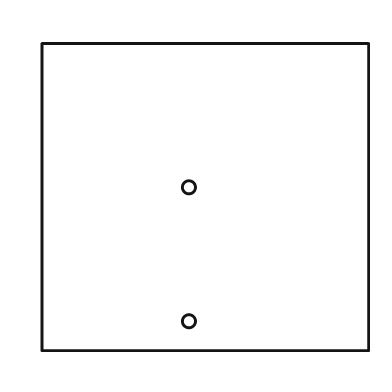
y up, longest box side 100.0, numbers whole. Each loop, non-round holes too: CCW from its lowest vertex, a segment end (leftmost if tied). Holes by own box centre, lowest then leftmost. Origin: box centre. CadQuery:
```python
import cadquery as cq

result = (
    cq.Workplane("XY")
    .moveTo(-50.0, -47.0)
    .lineTo(50.0, -47.0)
    .lineTo(50.0, 47.0)
    .lineTo(-50.0, 47.0)
    .close()
    .moveTo(-5.0, -38.0)
    .circle(2.0)
    .moveTo(-5.0, 3.0)
    .circle(2.0)
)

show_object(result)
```